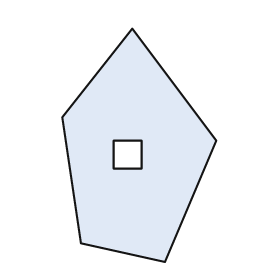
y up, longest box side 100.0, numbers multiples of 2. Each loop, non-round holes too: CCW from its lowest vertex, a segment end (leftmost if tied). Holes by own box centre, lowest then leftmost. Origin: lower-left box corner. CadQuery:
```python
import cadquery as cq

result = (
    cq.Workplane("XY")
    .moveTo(44.0, 0.0)
    .lineTo(66.0, 52.0)
    .lineTo(30.0, 100.0)
    .lineTo(0.0, 62.0)
    .lineTo(8.0, 8.0)
    .close()
    .moveTo(22.0, 40.0)
    .lineTo(34.0, 40.0)
    .lineTo(34.0, 52.0)
    .lineTo(22.0, 52.0)
    .close()
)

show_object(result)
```